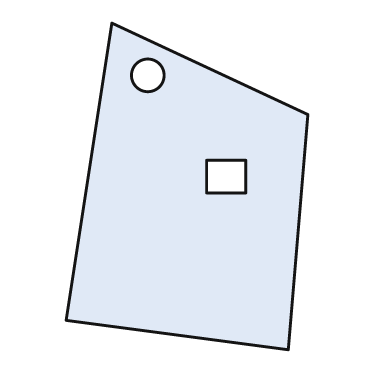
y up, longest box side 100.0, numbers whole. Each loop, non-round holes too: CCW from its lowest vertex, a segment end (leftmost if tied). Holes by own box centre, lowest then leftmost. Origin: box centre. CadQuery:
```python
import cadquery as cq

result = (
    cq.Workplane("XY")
    .moveTo(31.0, -50.0)
    .lineTo(37.0, 22.0)
    .lineTo(-23.0, 50.0)
    .lineTo(-37.0, -41.0)
    .close()
    .moveTo(6.0, -2.0)
    .lineTo(18.0, -2.0)
    .lineTo(18.0, 8.0)
    .lineTo(6.0, 8.0)
    .close()
    .moveTo(-12.0, 34.0)
    .circle(5.0)
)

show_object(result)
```